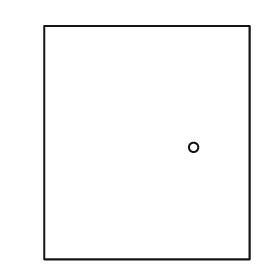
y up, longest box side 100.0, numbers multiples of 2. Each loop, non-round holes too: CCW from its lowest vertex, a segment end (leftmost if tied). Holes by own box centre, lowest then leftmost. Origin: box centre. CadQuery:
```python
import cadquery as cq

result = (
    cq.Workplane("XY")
    .moveTo(-44.0, -50.0)
    .lineTo(44.0, -50.0)
    .lineTo(44.0, 50.0)
    .lineTo(-44.0, 50.0)
    .close()
    .moveTo(20.0, -2.0)
    .circle(2.0)
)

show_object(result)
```